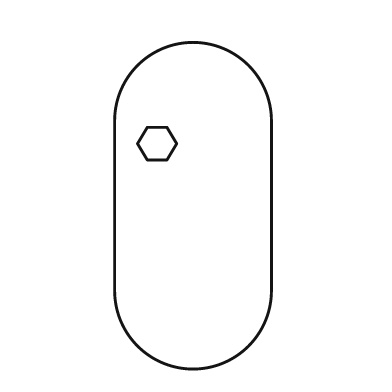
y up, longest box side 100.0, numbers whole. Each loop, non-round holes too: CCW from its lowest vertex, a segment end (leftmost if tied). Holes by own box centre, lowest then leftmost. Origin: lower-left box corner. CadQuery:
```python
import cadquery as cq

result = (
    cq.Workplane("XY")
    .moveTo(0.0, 24.0)
    .threePointArc((24.0, 0.0), (48.0, 24.0))
    .lineTo(48.0, 76.0)
    .threePointArc((24.0, 100.0), (0.0, 76.0))
    .close()
    .moveTo(10.0, 64.0)
    .lineTo(16.0, 64.0)
    .lineTo(19.0, 69.0)
    .lineTo(16.0, 74.0)
    .lineTo(10.0, 74.0)
    .lineTo(7.0, 69.0)
    .close()
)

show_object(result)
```